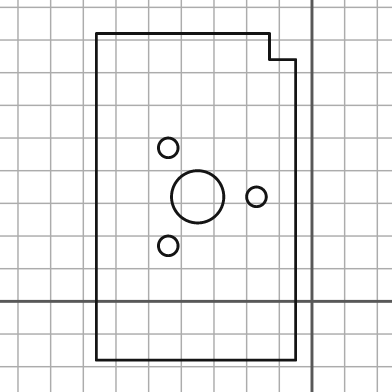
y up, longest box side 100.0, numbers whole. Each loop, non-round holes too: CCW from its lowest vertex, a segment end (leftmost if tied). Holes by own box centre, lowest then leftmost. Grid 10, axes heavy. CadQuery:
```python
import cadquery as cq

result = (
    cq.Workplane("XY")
    .moveTo(-66.0, -18.0)
    .lineTo(-5.0, -18.0)
    .lineTo(-5.0, 74.0)
    .lineTo(-13.0, 74.0)
    .lineTo(-13.0, 82.0)
    .lineTo(-66.0, 82.0)
    .close()
    .moveTo(-44.0, 17.0)
    .circle(3.0)
    .moveTo(-35.0, 32.0)
    .circle(8.0)
    .moveTo(-17.0, 32.0)
    .circle(3.0)
    .moveTo(-44.0, 47.0)
    .circle(3.0)
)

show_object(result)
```